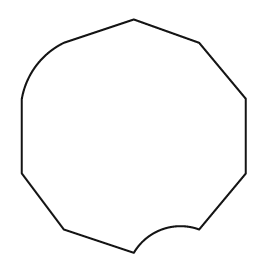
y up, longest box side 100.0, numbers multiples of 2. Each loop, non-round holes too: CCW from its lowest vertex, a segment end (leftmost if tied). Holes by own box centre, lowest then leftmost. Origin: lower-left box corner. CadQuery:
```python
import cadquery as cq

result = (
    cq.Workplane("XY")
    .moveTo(48.0, 0.0)
    .threePointArc((60.0, 10.0), (76.0, 10.0))
    .lineTo(96.0, 34.0)
    .lineTo(96.0, 66.0)
    .lineTo(76.0, 90.0)
    .lineTo(48.0, 100.0)
    .lineTo(18.0, 90.0)
    .threePointArc((6.0, 80.0), (0.0, 66.0))
    .lineTo(0.0, 34.0)
    .lineTo(18.0, 10.0)
    .close()
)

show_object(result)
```